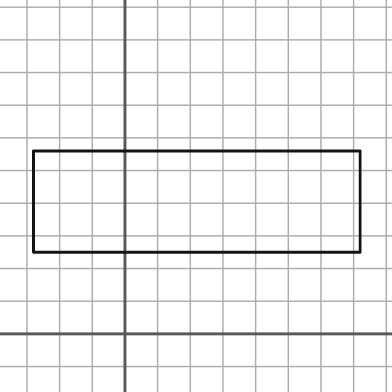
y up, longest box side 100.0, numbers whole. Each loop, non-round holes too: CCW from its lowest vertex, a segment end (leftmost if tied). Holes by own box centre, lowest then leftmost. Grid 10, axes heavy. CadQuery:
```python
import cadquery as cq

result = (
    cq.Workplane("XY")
    .moveTo(-28.0, 25.0)
    .lineTo(72.0, 25.0)
    .lineTo(72.0, 56.0)
    .lineTo(-28.0, 56.0)
    .close()
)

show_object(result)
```